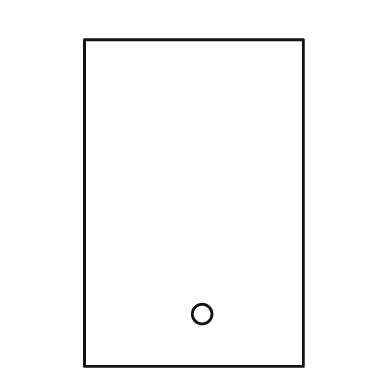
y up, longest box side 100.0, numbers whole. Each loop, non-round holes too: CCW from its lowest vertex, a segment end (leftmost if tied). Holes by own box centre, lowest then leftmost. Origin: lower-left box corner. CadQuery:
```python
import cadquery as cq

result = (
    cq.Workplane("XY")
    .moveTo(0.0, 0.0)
    .lineTo(67.0, 0.0)
    .lineTo(67.0, 100.0)
    .lineTo(0.0, 100.0)
    .close()
    .moveTo(36.0, 16.0)
    .circle(3.0)
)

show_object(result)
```